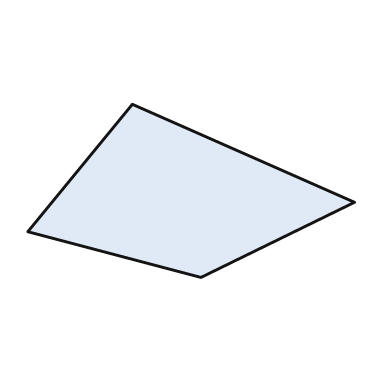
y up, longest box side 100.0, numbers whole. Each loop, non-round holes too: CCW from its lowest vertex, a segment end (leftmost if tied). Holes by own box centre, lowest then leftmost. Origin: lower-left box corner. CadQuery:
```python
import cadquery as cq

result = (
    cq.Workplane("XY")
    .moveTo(53.0, 0.0)
    .lineTo(100.0, 23.0)
    .lineTo(32.0, 53.0)
    .lineTo(0.0, 14.0)
    .close()
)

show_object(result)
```